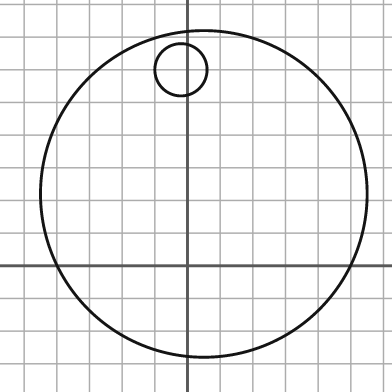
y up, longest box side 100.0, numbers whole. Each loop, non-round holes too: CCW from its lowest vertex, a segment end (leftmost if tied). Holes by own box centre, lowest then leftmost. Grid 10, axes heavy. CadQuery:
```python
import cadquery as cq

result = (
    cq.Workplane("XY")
    .moveTo(5.0, 22.0)
    .circle(50.0)
    .moveTo(-2.0, 60.0)
    .circle(8.0)
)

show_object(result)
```